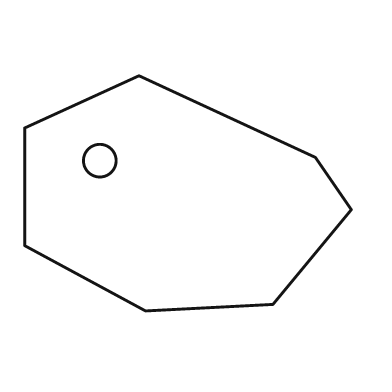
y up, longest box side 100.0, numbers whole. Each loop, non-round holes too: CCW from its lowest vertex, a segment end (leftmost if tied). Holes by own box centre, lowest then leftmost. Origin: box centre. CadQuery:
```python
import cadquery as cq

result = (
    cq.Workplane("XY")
    .moveTo(-13.0, -36.0)
    .lineTo(26.0, -34.0)
    .lineTo(50.0, -5.0)
    .lineTo(39.0, 11.0)
    .lineTo(-15.0, 36.0)
    .lineTo(-50.0, 20.0)
    .lineTo(-50.0, -16.0)
    .close()
    .moveTo(-27.0, 10.0)
    .circle(5.0)
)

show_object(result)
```